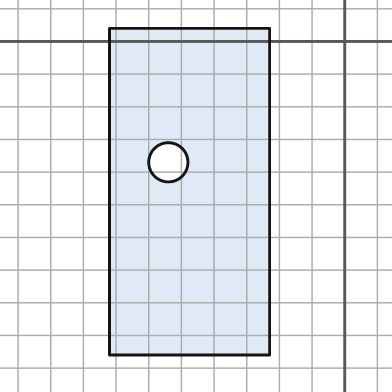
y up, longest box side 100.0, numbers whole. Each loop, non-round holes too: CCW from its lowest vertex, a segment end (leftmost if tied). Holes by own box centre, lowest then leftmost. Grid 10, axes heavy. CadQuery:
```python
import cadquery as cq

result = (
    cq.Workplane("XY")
    .moveTo(-72.0, -96.0)
    .lineTo(-23.0, -96.0)
    .lineTo(-23.0, 4.0)
    .lineTo(-72.0, 4.0)
    .close()
    .moveTo(-54.0, -37.0)
    .circle(6.0)
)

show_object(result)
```